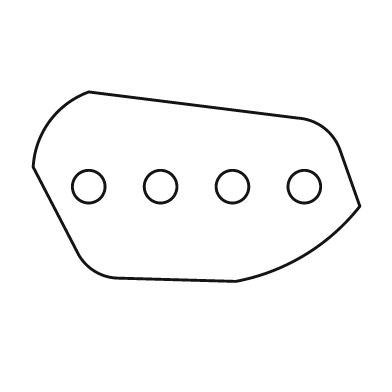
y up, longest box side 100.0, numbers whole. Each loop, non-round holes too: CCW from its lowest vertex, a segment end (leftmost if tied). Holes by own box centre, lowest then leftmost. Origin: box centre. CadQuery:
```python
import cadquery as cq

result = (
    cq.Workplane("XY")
    .moveTo(12.0, -29.0)
    .threePointArc((33.0, -21.0), (50.0, -6.0))
    .lineTo(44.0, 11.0)
    .threePointArc((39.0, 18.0), (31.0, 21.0))
    .lineTo(-33.0, 29.0)
    .threePointArc((-45.0, 20.0), (-50.0, 6.0))
    .lineTo(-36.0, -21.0)
    .threePointArc((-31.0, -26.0), (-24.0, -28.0))
    .close()
    .moveTo(-33.0, 0.0)
    .circle(5.0)
    .moveTo(-11.0, 0.0)
    .circle(5.0)
    .moveTo(11.0, 0.0)
    .circle(5.0)
    .moveTo(33.0, 0.0)
    .circle(5.0)
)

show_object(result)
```